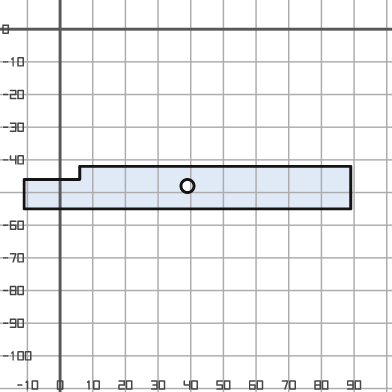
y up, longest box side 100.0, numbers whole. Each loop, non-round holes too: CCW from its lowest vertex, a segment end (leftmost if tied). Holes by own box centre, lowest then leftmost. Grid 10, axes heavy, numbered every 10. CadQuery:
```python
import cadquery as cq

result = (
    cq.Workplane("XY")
    .moveTo(-11.0, -55.0)
    .lineTo(89.0, -55.0)
    .lineTo(89.0, -42.0)
    .lineTo(6.0, -42.0)
    .lineTo(6.0, -46.0)
    .lineTo(-11.0, -46.0)
    .close()
    .moveTo(39.0, -48.0)
    .circle(2.0)
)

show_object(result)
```